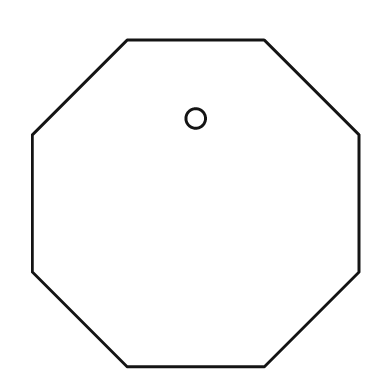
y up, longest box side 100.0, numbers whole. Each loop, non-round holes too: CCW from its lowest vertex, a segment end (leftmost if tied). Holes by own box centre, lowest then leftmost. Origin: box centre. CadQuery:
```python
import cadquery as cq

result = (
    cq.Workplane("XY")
    .moveTo(-21.0, -50.0)
    .lineTo(21.0, -50.0)
    .lineTo(50.0, -21.0)
    .lineTo(50.0, 21.0)
    .lineTo(21.0, 50.0)
    .lineTo(-21.0, 50.0)
    .lineTo(-50.0, 21.0)
    .lineTo(-50.0, -21.0)
    .close()
    .moveTo(0.0, 26.0)
    .circle(3.0)
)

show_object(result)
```